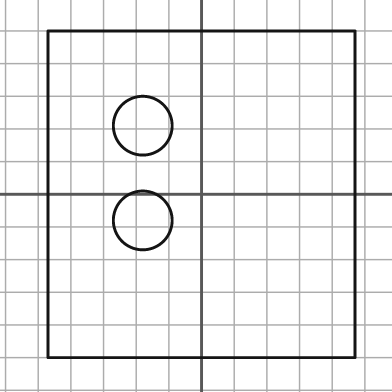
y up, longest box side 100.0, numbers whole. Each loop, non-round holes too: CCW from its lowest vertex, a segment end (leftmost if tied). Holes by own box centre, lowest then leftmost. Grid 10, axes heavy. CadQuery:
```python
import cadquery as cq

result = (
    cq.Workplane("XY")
    .moveTo(-47.0, -50.0)
    .lineTo(47.0, -50.0)
    .lineTo(47.0, 50.0)
    .lineTo(-47.0, 50.0)
    .close()
    .moveTo(-18.0, -8.0)
    .circle(9.0)
    .moveTo(-18.0, 21.0)
    .circle(9.0)
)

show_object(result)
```